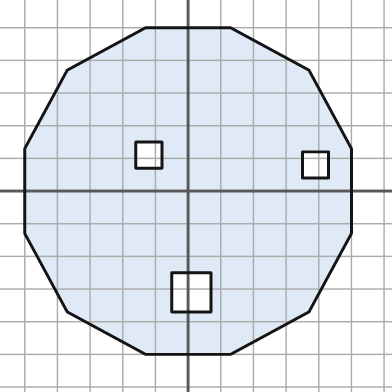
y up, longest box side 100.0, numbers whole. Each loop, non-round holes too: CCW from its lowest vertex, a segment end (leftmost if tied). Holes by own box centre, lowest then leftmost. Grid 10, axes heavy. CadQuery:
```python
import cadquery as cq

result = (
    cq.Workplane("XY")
    .moveTo(-13.0, -50.0)
    .lineTo(13.0, -50.0)
    .lineTo(37.0, -37.0)
    .lineTo(50.0, -13.0)
    .lineTo(50.0, 13.0)
    .lineTo(37.0, 37.0)
    .lineTo(13.0, 50.0)
    .lineTo(-13.0, 50.0)
    .lineTo(-37.0, 37.0)
    .lineTo(-50.0, 13.0)
    .lineTo(-50.0, -13.0)
    .lineTo(-37.0, -37.0)
    .close()
    .moveTo(-5.0, -37.0)
    .lineTo(7.0, -37.0)
    .lineTo(7.0, -25.0)
    .lineTo(-5.0, -25.0)
    .close()
    .moveTo(35.0, 4.0)
    .lineTo(43.0, 4.0)
    .lineTo(43.0, 12.0)
    .lineTo(35.0, 12.0)
    .close()
    .moveTo(-16.0, 7.0)
    .lineTo(-8.0, 7.0)
    .lineTo(-8.0, 15.0)
    .lineTo(-16.0, 15.0)
    .close()
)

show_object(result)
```